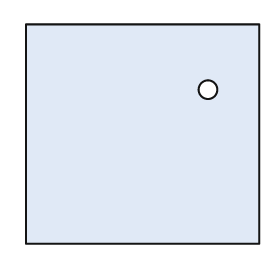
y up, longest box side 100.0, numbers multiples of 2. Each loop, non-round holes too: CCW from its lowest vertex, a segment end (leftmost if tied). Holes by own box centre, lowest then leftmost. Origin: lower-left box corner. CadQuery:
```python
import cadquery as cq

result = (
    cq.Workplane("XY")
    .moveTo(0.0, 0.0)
    .lineTo(100.0, 0.0)
    .lineTo(100.0, 94.0)
    .lineTo(0.0, 94.0)
    .close()
    .moveTo(78.0, 66.0)
    .circle(4.0)
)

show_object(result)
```